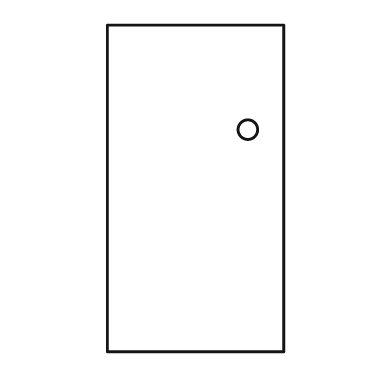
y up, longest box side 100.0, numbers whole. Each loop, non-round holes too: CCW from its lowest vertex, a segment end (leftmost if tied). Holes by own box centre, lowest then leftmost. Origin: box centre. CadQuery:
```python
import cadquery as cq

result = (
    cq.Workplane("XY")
    .moveTo(-27.0, -50.0)
    .lineTo(27.0, -50.0)
    .lineTo(27.0, 50.0)
    .lineTo(-27.0, 50.0)
    .close()
    .moveTo(16.0, 18.0)
    .circle(3.0)
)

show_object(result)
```